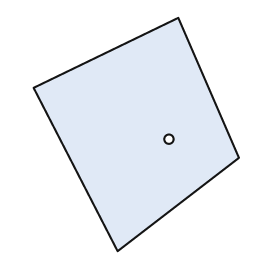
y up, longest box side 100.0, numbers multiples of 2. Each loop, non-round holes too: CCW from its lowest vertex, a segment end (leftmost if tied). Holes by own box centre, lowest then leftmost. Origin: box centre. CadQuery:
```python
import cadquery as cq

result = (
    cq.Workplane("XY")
    .moveTo(-8.0, -50.0)
    .lineTo(44.0, -10.0)
    .lineTo(18.0, 50.0)
    .lineTo(-44.0, 20.0)
    .close()
    .moveTo(14.0, -2.0)
    .circle(2.0)
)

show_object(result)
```